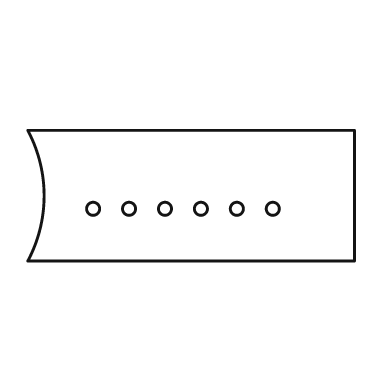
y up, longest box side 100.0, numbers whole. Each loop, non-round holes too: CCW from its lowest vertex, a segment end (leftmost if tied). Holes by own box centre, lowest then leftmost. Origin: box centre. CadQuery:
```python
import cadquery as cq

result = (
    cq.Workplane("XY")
    .moveTo(-50.0, -20.0)
    .lineTo(50.0, -20.0)
    .lineTo(50.0, 20.0)
    .lineTo(-50.0, 20.0)
    .threePointArc((-45.0, 0.0), (-50.0, -20.0))
    .close()
    .moveTo(-30.0, -4.0)
    .circle(2.0)
    .moveTo(-19.0, -4.0)
    .circle(2.0)
    .moveTo(-8.0, -4.0)
    .circle(2.0)
    .moveTo(3.0, -4.0)
    .circle(2.0)
    .moveTo(14.0, -4.0)
    .circle(2.0)
    .moveTo(25.0, -4.0)
    .circle(2.0)
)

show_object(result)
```